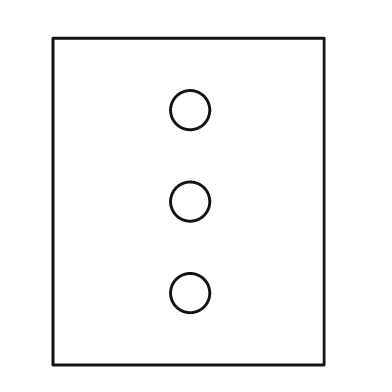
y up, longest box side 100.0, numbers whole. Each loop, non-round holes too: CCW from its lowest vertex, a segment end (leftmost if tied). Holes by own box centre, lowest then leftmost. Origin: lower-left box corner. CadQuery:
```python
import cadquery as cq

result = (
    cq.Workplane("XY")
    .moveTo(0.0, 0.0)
    .lineTo(83.0, 0.0)
    .lineTo(83.0, 100.0)
    .lineTo(0.0, 100.0)
    .close()
    .moveTo(42.0, 22.0)
    .circle(6.0)
    .moveTo(42.0, 50.0)
    .circle(6.0)
    .moveTo(42.0, 78.0)
    .circle(6.0)
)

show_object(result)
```